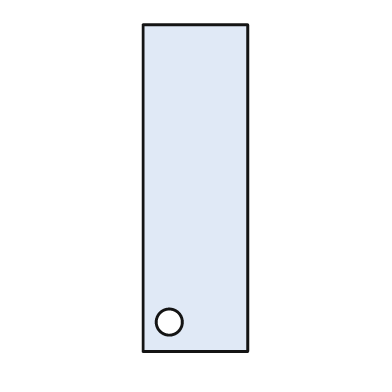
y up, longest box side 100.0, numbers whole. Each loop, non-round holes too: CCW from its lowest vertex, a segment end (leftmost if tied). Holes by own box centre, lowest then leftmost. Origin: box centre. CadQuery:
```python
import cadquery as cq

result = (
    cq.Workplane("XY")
    .moveTo(-16.0, -50.0)
    .lineTo(16.0, -50.0)
    .lineTo(16.0, 50.0)
    .lineTo(-16.0, 50.0)
    .close()
    .moveTo(-8.0, -41.0)
    .circle(4.0)
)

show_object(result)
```